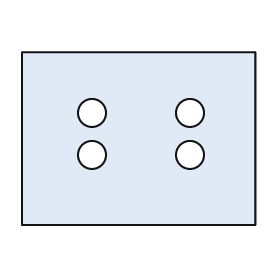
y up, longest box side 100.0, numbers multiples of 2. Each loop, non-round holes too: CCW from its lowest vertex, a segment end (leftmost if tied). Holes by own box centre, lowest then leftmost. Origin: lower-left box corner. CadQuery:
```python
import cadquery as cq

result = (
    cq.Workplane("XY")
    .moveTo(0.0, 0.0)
    .lineTo(100.0, 0.0)
    .lineTo(100.0, 74.0)
    .lineTo(0.0, 74.0)
    .close()
    .moveTo(30.0, 30.0)
    .circle(6.0)
    .moveTo(72.0, 30.0)
    .circle(6.0)
    .moveTo(30.0, 48.0)
    .circle(6.0)
    .moveTo(72.0, 48.0)
    .circle(6.0)
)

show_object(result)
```